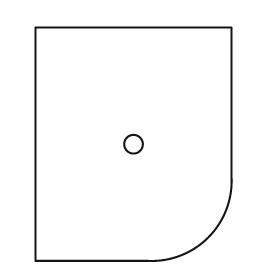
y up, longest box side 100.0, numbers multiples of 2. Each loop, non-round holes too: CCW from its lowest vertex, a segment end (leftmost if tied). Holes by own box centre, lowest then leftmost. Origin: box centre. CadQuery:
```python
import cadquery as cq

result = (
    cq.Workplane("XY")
    .moveTo(-42.0, -50.0)
    .lineTo(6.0, -50.0)
    .threePointArc((32.0, -40.0), (42.0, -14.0))
    .lineTo(42.0, 50.0)
    .lineTo(-42.0, 50.0)
    .close()
    .moveTo(0.0, 0.0)
    .circle(4.0)
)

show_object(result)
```